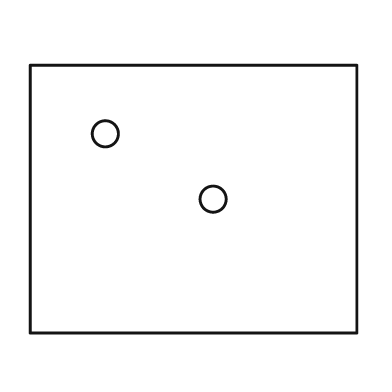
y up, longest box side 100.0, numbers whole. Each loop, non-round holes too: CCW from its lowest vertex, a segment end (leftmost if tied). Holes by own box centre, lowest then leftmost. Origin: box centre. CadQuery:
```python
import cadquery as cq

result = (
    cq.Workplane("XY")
    .moveTo(-50.0, -41.0)
    .lineTo(50.0, -41.0)
    .lineTo(50.0, 41.0)
    .lineTo(-50.0, 41.0)
    .close()
    .moveTo(6.0, 0.0)
    .circle(4.0)
    .moveTo(-27.0, 20.0)
    .circle(4.0)
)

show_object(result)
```